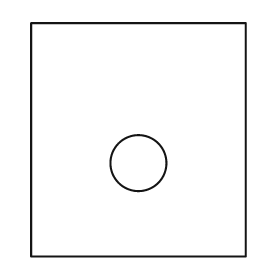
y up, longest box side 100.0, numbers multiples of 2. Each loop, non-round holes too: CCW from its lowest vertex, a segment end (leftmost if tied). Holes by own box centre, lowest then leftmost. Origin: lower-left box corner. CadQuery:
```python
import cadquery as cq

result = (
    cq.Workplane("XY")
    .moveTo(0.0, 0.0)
    .lineTo(92.0, 0.0)
    .lineTo(92.0, 100.0)
    .lineTo(0.0, 100.0)
    .close()
    .moveTo(46.0, 40.0)
    .circle(12.0)
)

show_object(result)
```